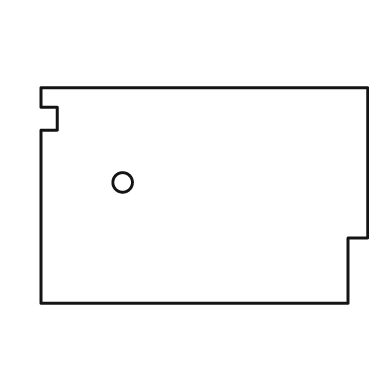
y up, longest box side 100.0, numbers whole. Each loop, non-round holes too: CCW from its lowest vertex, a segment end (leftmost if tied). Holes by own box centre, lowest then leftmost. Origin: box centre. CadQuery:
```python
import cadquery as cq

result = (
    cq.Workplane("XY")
    .moveTo(-50.0, -33.0)
    .lineTo(44.0, -33.0)
    .lineTo(44.0, -13.0)
    .lineTo(50.0, -13.0)
    .lineTo(50.0, 33.0)
    .lineTo(-50.0, 33.0)
    .lineTo(-50.0, 27.0)
    .lineTo(-45.0, 27.0)
    .lineTo(-45.0, 20.0)
    .lineTo(-50.0, 20.0)
    .close()
    .moveTo(-25.0, 4.0)
    .circle(3.0)
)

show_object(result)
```